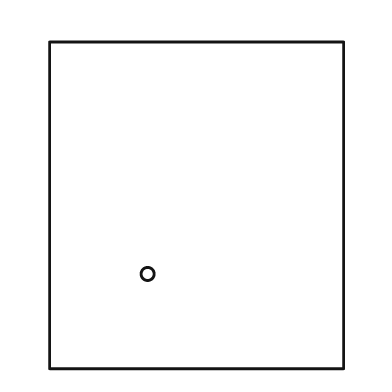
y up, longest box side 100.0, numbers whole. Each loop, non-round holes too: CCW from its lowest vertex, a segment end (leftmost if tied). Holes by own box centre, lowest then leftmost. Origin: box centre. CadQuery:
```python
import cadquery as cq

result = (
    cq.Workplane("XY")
    .moveTo(-45.0, -50.0)
    .lineTo(45.0, -50.0)
    .lineTo(45.0, 50.0)
    .lineTo(-45.0, 50.0)
    .close()
    .moveTo(-15.0, -21.0)
    .circle(2.0)
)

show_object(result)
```